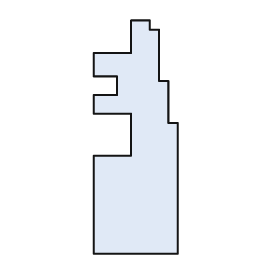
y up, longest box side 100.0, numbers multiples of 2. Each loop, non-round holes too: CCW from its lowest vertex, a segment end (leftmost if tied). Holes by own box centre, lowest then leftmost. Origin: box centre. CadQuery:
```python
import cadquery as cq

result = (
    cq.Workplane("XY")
    .moveTo(-18.0, -50.0)
    .lineTo(18.0, -50.0)
    .lineTo(18.0, 6.0)
    .lineTo(14.0, 6.0)
    .lineTo(14.0, 24.0)
    .lineTo(10.0, 24.0)
    .lineTo(10.0, 46.0)
    .lineTo(6.0, 46.0)
    .lineTo(6.0, 50.0)
    .lineTo(-2.0, 50.0)
    .lineTo(-2.0, 36.0)
    .lineTo(-18.0, 36.0)
    .lineTo(-18.0, 26.0)
    .lineTo(-8.0, 26.0)
    .lineTo(-8.0, 18.0)
    .lineTo(-18.0, 18.0)
    .lineTo(-18.0, 10.0)
    .lineTo(-2.0, 10.0)
    .lineTo(-2.0, -8.0)
    .lineTo(-18.0, -8.0)
    .close()
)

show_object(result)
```